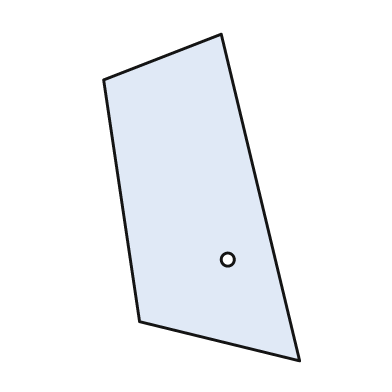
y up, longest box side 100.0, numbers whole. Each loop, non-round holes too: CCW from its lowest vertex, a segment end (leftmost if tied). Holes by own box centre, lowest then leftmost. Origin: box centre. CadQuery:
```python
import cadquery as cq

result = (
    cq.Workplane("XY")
    .moveTo(30.0, -50.0)
    .lineTo(6.0, 50.0)
    .lineTo(-30.0, 36.0)
    .lineTo(-19.0, -38.0)
    .close()
    .moveTo(8.0, -19.0)
    .circle(2.0)
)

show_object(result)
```